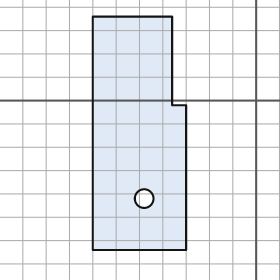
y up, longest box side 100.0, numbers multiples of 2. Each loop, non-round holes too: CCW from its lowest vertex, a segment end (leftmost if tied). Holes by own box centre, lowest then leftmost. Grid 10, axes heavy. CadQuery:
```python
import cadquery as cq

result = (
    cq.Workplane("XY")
    .moveTo(-70.0, -64.0)
    .lineTo(-30.0, -64.0)
    .lineTo(-30.0, -2.0)
    .lineTo(-36.0, -2.0)
    .lineTo(-36.0, 36.0)
    .lineTo(-70.0, 36.0)
    .close()
    .moveTo(-48.0, -42.0)
    .circle(4.0)
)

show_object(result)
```